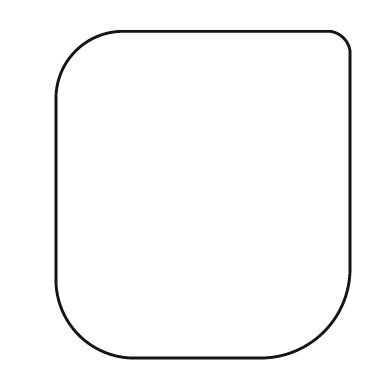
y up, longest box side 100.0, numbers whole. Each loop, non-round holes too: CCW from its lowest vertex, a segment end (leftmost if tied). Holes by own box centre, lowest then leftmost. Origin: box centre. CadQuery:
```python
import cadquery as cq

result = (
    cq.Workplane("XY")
    .moveTo(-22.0, -50.0)
    .lineTo(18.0, -50.0)
    .threePointArc((37.0, -42.0), (45.0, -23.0))
    .lineTo(45.0, 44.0)
    .threePointArc((43.0, 48.0), (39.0, 50.0))
    .lineTo(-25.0, 50.0)
    .threePointArc((-39.0, 44.0), (-45.0, 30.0))
    .lineTo(-45.0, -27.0)
    .threePointArc((-38.0, -43.0), (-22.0, -50.0))
    .close()
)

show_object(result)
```